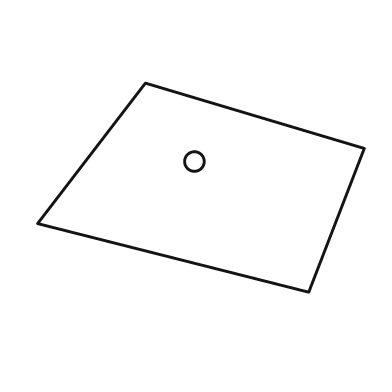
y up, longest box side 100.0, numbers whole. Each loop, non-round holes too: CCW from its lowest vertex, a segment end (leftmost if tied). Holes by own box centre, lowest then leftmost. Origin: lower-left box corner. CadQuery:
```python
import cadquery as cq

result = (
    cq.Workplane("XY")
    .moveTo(83.0, 0.0)
    .lineTo(100.0, 44.0)
    .lineTo(33.0, 64.0)
    .lineTo(0.0, 21.0)
    .close()
    .moveTo(48.0, 40.0)
    .circle(3.0)
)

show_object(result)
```